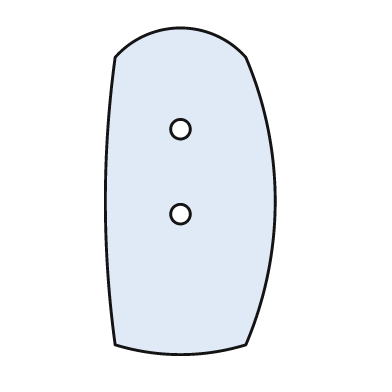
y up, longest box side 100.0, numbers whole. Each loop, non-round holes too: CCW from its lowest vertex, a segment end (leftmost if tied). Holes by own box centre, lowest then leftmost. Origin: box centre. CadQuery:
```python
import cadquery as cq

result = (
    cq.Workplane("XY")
    .moveTo(-23.0, -47.0)
    .threePointArc((-3.0, -50.0), (17.0, -47.0))
    .threePointArc((26.0, -3.0), (17.0, 41.0))
    .threePointArc((-3.0, 50.0), (-23.0, 41.0))
    .threePointArc((-26.0, -3.0), (-23.0, -47.0))
    .close()
    .moveTo(-3.0, -7.0)
    .circle(3.0)
    .moveTo(-3.0, 19.0)
    .circle(3.0)
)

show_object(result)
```